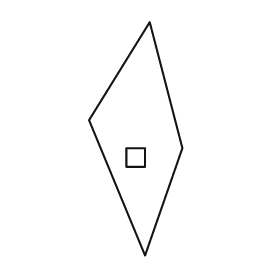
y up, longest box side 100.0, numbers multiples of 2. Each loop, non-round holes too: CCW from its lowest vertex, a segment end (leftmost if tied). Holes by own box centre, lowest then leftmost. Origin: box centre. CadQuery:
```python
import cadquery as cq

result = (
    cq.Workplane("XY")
    .moveTo(4.0, -50.0)
    .lineTo(20.0, -4.0)
    .lineTo(6.0, 50.0)
    .lineTo(-20.0, 8.0)
    .close()
    .moveTo(-4.0, -12.0)
    .lineTo(4.0, -12.0)
    .lineTo(4.0, -4.0)
    .lineTo(-4.0, -4.0)
    .close()
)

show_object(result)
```